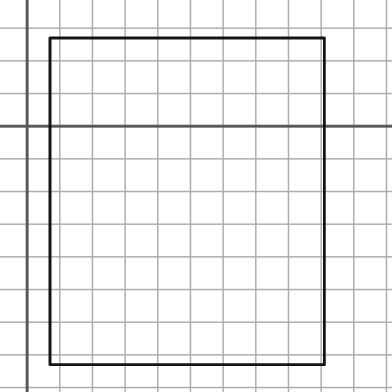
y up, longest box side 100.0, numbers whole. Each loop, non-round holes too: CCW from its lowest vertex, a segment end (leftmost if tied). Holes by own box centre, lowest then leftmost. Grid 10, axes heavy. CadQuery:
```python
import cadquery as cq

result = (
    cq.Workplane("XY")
    .moveTo(7.0, -73.0)
    .lineTo(91.0, -73.0)
    .lineTo(91.0, 27.0)
    .lineTo(7.0, 27.0)
    .close()
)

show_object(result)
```